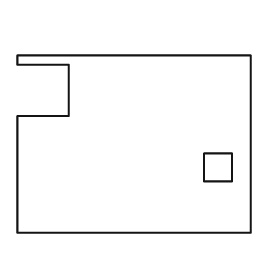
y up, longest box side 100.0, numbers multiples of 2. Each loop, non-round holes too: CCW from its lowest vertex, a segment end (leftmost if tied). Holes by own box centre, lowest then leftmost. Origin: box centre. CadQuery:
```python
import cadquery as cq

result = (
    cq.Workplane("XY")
    .moveTo(-50.0, -38.0)
    .lineTo(50.0, -38.0)
    .lineTo(50.0, 38.0)
    .lineTo(-50.0, 38.0)
    .lineTo(-50.0, 34.0)
    .lineTo(-28.0, 34.0)
    .lineTo(-28.0, 12.0)
    .lineTo(-50.0, 12.0)
    .close()
    .moveTo(30.0, -16.0)
    .lineTo(42.0, -16.0)
    .lineTo(42.0, -4.0)
    .lineTo(30.0, -4.0)
    .close()
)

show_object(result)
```